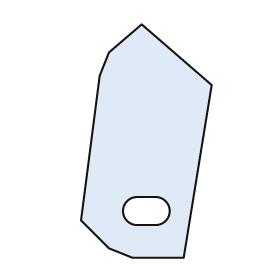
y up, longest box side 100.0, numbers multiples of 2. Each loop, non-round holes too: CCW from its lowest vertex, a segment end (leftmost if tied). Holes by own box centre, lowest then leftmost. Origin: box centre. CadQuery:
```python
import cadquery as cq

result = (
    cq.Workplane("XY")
    .moveTo(-6.0, -50.0)
    .lineTo(16.0, -50.0)
    .lineTo(28.0, 24.0)
    .lineTo(-2.0, 50.0)
    .lineTo(-16.0, 38.0)
    .lineTo(-20.0, 28.0)
    .lineTo(-28.0, -34.0)
    .lineTo(-16.0, -46.0)
    .close()
    .moveTo(-4.0, -36.0)
    .lineTo(4.0, -36.0)
    .threePointArc((10.0, -30.0), (4.0, -24.0))
    .lineTo(-4.0, -24.0)
    .threePointArc((-10.0, -30.0), (-4.0, -36.0))
    .close()
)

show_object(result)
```